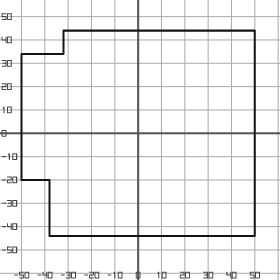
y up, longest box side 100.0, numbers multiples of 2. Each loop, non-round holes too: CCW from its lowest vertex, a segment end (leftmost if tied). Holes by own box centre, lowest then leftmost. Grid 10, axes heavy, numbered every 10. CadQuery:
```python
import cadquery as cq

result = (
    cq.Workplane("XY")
    .moveTo(-38.0, -44.0)
    .lineTo(50.0, -44.0)
    .lineTo(50.0, 44.0)
    .lineTo(-32.0, 44.0)
    .lineTo(-32.0, 34.0)
    .lineTo(-50.0, 34.0)
    .lineTo(-50.0, -20.0)
    .lineTo(-38.0, -20.0)
    .close()
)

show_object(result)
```